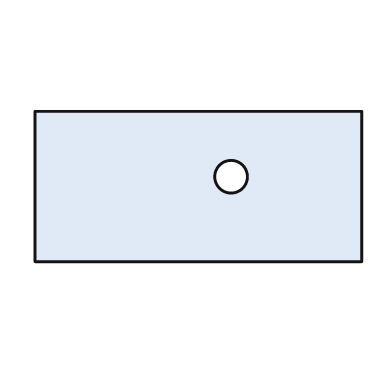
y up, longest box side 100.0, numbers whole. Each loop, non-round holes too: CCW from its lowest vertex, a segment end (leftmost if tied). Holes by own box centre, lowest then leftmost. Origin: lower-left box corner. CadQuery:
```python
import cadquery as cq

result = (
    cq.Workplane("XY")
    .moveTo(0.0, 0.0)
    .lineTo(100.0, 0.0)
    .lineTo(100.0, 46.0)
    .lineTo(0.0, 46.0)
    .close()
    .moveTo(60.0, 26.0)
    .circle(5.0)
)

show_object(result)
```